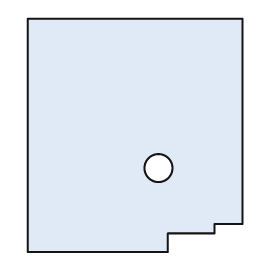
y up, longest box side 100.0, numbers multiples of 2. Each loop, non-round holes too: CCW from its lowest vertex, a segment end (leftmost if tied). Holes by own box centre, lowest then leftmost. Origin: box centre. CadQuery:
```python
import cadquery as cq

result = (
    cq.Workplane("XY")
    .moveTo(-46.0, -50.0)
    .lineTo(14.0, -50.0)
    .lineTo(14.0, -42.0)
    .lineTo(34.0, -42.0)
    .lineTo(34.0, -38.0)
    .lineTo(46.0, -38.0)
    .lineTo(46.0, 50.0)
    .lineTo(-46.0, 50.0)
    .close()
    .moveTo(10.0, -14.0)
    .circle(6.0)
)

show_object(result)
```